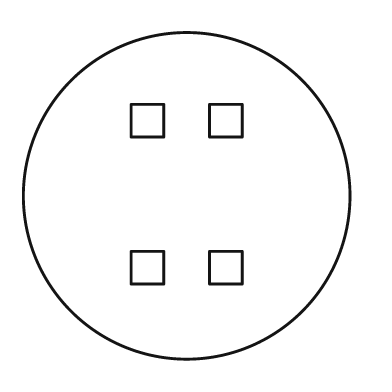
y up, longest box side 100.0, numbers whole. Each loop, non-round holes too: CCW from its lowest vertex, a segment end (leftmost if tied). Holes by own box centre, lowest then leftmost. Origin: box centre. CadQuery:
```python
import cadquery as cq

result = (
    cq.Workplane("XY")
    .moveTo(0.0, 0.0)
    .circle(50.0)
    .moveTo(-17.0, -27.0)
    .lineTo(-7.0, -27.0)
    .lineTo(-7.0, -17.0)
    .lineTo(-17.0, -17.0)
    .close()
    .moveTo(7.0, -27.0)
    .lineTo(17.0, -27.0)
    .lineTo(17.0, -17.0)
    .lineTo(7.0, -17.0)
    .close()
    .moveTo(-17.0, 18.0)
    .lineTo(-7.0, 18.0)
    .lineTo(-7.0, 28.0)
    .lineTo(-17.0, 28.0)
    .close()
    .moveTo(7.0, 18.0)
    .lineTo(17.0, 18.0)
    .lineTo(17.0, 28.0)
    .lineTo(7.0, 28.0)
    .close()
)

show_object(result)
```